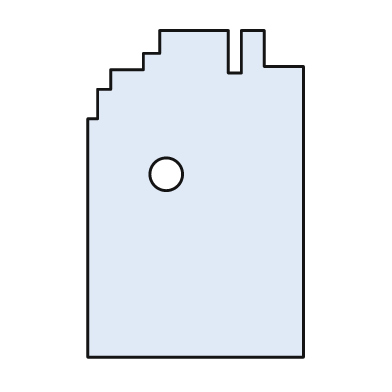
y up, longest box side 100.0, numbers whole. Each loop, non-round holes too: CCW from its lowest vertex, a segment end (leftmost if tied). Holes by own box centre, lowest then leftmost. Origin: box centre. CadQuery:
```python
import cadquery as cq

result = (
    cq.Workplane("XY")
    .moveTo(-33.0, -50.0)
    .lineTo(33.0, -50.0)
    .lineTo(33.0, 39.0)
    .lineTo(21.0, 39.0)
    .lineTo(21.0, 50.0)
    .lineTo(14.0, 50.0)
    .lineTo(14.0, 37.0)
    .lineTo(10.0, 37.0)
    .lineTo(10.0, 50.0)
    .lineTo(-11.0, 50.0)
    .lineTo(-11.0, 43.0)
    .lineTo(-16.0, 43.0)
    .lineTo(-16.0, 38.0)
    .lineTo(-26.0, 38.0)
    .lineTo(-26.0, 32.0)
    .lineTo(-30.0, 32.0)
    .lineTo(-30.0, 23.0)
    .lineTo(-33.0, 23.0)
    .close()
    .moveTo(-9.0, 6.0)
    .circle(5.0)
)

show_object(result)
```